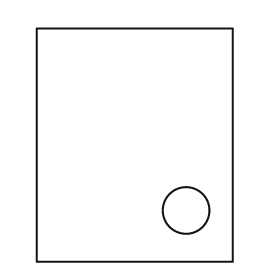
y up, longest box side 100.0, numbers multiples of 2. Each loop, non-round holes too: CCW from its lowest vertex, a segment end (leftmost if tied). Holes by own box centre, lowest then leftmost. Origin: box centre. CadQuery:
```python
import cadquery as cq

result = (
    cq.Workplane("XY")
    .moveTo(-42.0, -50.0)
    .lineTo(42.0, -50.0)
    .lineTo(42.0, 50.0)
    .lineTo(-42.0, 50.0)
    .close()
    .moveTo(22.0, -28.0)
    .circle(10.0)
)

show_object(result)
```